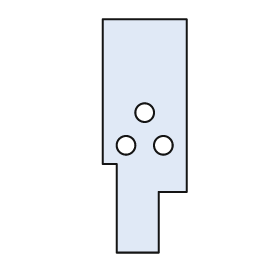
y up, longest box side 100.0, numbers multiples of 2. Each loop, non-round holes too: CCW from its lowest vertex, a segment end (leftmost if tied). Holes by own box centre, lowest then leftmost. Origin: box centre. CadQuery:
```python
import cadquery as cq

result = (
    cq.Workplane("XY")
    .moveTo(-12.0, -50.0)
    .lineTo(6.0, -50.0)
    .lineTo(6.0, -24.0)
    .lineTo(18.0, -24.0)
    .lineTo(18.0, 50.0)
    .lineTo(-18.0, 50.0)
    .lineTo(-18.0, -12.0)
    .lineTo(-12.0, -12.0)
    .close()
    .moveTo(-8.0, -4.0)
    .circle(4.0)
    .moveTo(8.0, -4.0)
    .circle(4.0)
    .moveTo(0.0, 10.0)
    .circle(4.0)
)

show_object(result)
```